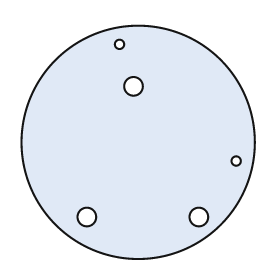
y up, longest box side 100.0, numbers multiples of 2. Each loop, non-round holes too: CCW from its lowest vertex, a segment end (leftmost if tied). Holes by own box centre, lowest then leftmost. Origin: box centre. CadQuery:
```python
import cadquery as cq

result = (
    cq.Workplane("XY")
    .moveTo(0.0, 0.0)
    .circle(50.0)
    .moveTo(-22.0, -32.0)
    .circle(4.0)
    .moveTo(26.0, -32.0)
    .circle(4.0)
    .moveTo(42.0, -8.0)
    .circle(2.0)
    .moveTo(-2.0, 24.0)
    .circle(4.0)
    .moveTo(-8.0, 42.0)
    .circle(2.0)
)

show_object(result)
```